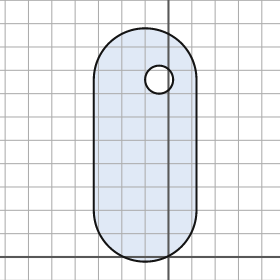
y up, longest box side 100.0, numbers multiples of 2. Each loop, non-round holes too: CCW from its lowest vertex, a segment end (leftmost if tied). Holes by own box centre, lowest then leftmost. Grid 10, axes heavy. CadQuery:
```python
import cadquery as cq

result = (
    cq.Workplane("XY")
    .moveTo(-32.0, 20.0)
    .threePointArc((-10.0, -2.0), (12.0, 20.0))
    .lineTo(12.0, 76.0)
    .threePointArc((-10.0, 98.0), (-32.0, 76.0))
    .close()
    .moveTo(-4.0, 76.0)
    .circle(6.0)
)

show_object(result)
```